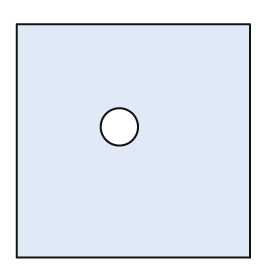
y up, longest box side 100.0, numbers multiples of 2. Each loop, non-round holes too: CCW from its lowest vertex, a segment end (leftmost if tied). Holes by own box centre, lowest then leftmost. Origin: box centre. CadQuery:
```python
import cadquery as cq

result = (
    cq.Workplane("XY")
    .moveTo(-50.0, -50.0)
    .lineTo(50.0, -50.0)
    .lineTo(50.0, 50.0)
    .lineTo(-50.0, 50.0)
    .close()
    .moveTo(-6.0, 6.0)
    .circle(8.0)
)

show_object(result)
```